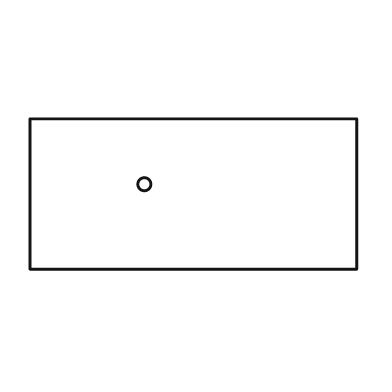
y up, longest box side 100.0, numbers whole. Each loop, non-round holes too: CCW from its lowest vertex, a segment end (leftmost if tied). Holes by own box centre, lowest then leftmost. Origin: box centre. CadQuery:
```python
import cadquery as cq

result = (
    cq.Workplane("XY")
    .moveTo(-50.0, -23.0)
    .lineTo(50.0, -23.0)
    .lineTo(50.0, 23.0)
    .lineTo(-50.0, 23.0)
    .close()
    .moveTo(-15.0, 3.0)
    .circle(2.0)
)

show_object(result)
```